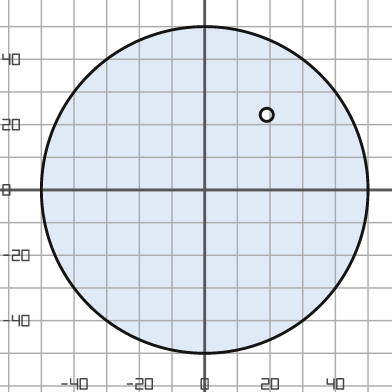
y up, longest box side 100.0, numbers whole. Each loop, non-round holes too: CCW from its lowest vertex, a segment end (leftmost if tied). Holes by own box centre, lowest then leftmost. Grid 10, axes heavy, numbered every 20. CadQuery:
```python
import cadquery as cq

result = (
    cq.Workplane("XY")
    .moveTo(0.0, 0.0)
    .circle(50.0)
    .moveTo(19.0, 23.0)
    .circle(2.0)
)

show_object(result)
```